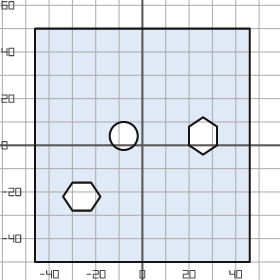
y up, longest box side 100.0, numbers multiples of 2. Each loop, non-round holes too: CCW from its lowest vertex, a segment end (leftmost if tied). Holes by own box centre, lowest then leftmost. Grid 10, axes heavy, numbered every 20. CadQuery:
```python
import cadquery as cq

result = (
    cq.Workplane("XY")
    .moveTo(-46.0, -50.0)
    .lineTo(46.0, -50.0)
    .lineTo(46.0, 50.0)
    .lineTo(-46.0, 50.0)
    .close()
    .moveTo(-30.0, -28.0)
    .lineTo(-22.0, -28.0)
    .lineTo(-18.0, -22.0)
    .lineTo(-22.0, -16.0)
    .lineTo(-30.0, -16.0)
    .lineTo(-34.0, -22.0)
    .close()
    .moveTo(-8.0, 4.0)
    .circle(6.0)
    .moveTo(26.0, -4.0)
    .lineTo(32.0, 0.0)
    .lineTo(32.0, 8.0)
    .lineTo(26.0, 12.0)
    .lineTo(20.0, 8.0)
    .lineTo(20.0, 0.0)
    .close()
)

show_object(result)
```